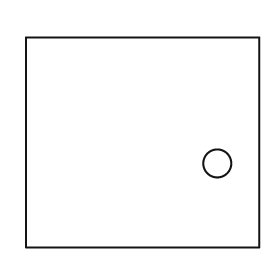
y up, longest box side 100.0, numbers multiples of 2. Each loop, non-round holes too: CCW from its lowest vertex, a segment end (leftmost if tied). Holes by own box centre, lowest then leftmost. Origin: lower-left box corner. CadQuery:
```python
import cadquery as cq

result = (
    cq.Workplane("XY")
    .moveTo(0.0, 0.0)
    .lineTo(100.0, 0.0)
    .lineTo(100.0, 90.0)
    .lineTo(0.0, 90.0)
    .close()
    .moveTo(82.0, 36.0)
    .circle(6.0)
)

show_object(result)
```